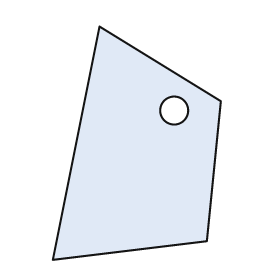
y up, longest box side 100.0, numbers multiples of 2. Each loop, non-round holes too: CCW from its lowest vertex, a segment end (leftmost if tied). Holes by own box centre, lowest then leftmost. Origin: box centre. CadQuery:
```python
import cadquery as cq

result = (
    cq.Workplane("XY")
    .moveTo(-36.0, -50.0)
    .lineTo(30.0, -42.0)
    .lineTo(36.0, 18.0)
    .lineTo(-16.0, 50.0)
    .close()
    .moveTo(16.0, 14.0)
    .circle(6.0)
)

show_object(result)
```